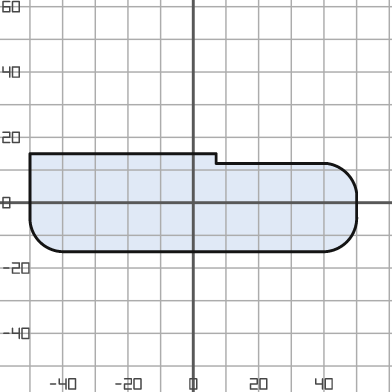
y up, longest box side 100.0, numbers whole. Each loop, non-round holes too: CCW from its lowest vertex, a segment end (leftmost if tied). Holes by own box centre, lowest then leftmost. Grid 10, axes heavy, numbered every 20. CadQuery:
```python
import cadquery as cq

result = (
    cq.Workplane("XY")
    .moveTo(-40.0, -15.0)
    .lineTo(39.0, -15.0)
    .threePointArc((47.0, -12.0), (50.0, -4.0))
    .lineTo(50.0, 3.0)
    .threePointArc((47.0, 9.0), (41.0, 12.0))
    .lineTo(7.0, 12.0)
    .lineTo(7.0, 15.0)
    .lineTo(-50.0, 15.0)
    .lineTo(-50.0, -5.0)
    .threePointArc((-47.0, -12.0), (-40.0, -15.0))
    .close()
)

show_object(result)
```